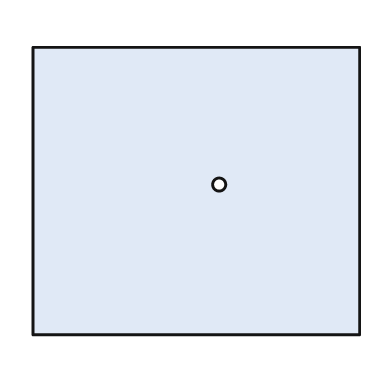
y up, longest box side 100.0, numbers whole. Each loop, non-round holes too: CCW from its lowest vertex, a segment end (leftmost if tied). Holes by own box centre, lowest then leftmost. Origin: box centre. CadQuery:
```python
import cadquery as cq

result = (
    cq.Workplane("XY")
    .moveTo(-50.0, -44.0)
    .lineTo(50.0, -44.0)
    .lineTo(50.0, 44.0)
    .lineTo(-50.0, 44.0)
    .close()
    .moveTo(7.0, 2.0)
    .circle(2.0)
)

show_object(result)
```